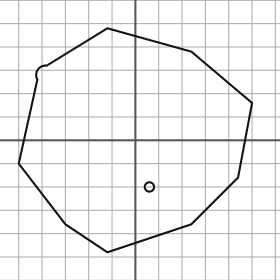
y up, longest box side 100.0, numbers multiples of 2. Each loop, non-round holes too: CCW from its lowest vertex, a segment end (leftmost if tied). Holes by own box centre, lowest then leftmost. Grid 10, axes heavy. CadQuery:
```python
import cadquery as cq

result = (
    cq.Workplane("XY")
    .moveTo(-12.0, -48.0)
    .lineTo(24.0, -36.0)
    .lineTo(44.0, -16.0)
    .lineTo(50.0, 16.0)
    .lineTo(24.0, 38.0)
    .lineTo(-12.0, 48.0)
    .lineTo(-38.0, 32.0)
    .threePointArc((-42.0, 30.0), (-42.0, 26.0))
    .lineTo(-50.0, -10.0)
    .lineTo(-30.0, -36.0)
    .close()
    .moveTo(6.0, -20.0)
    .circle(2.0)
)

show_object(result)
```